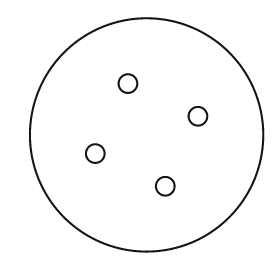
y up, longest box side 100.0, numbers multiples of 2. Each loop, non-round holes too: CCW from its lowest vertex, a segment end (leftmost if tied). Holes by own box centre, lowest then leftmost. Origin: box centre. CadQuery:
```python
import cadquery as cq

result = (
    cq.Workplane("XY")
    .moveTo(0.0, 0.0)
    .circle(50.0)
    .moveTo(8.0, -22.0)
    .circle(4.0)
    .moveTo(-22.0, -8.0)
    .circle(4.0)
    .moveTo(22.0, 8.0)
    .circle(4.0)
    .moveTo(-8.0, 22.0)
    .circle(4.0)
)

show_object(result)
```